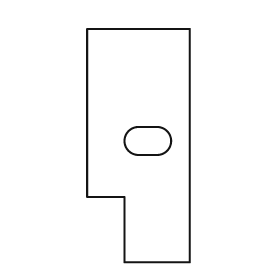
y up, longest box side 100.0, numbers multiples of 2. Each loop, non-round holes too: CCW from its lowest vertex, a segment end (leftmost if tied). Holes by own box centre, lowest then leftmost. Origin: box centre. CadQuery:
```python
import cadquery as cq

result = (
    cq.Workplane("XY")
    .moveTo(-6.0, -50.0)
    .lineTo(22.0, -50.0)
    .lineTo(22.0, 50.0)
    .lineTo(-22.0, 50.0)
    .lineTo(-22.0, -22.0)
    .lineTo(-6.0, -22.0)
    .close()
    .moveTo(0.0, -4.0)
    .lineTo(8.0, -4.0)
    .threePointArc((14.0, 2.0), (8.0, 8.0))
    .lineTo(0.0, 8.0)
    .threePointArc((-6.0, 2.0), (0.0, -4.0))
    .close()
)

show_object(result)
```